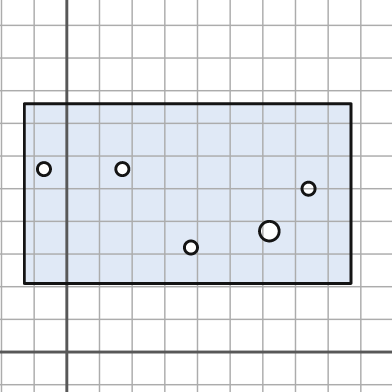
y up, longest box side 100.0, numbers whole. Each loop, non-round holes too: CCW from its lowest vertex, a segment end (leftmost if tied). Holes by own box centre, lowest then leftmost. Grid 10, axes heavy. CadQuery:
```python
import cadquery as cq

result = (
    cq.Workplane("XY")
    .moveTo(-13.0, 21.0)
    .lineTo(87.0, 21.0)
    .lineTo(87.0, 76.0)
    .lineTo(-13.0, 76.0)
    .close()
    .moveTo(38.0, 32.0)
    .circle(2.0)
    .moveTo(62.0, 37.0)
    .circle(3.0)
    .moveTo(74.0, 50.0)
    .circle(2.0)
    .moveTo(-7.0, 56.0)
    .circle(2.0)
    .moveTo(17.0, 56.0)
    .circle(2.0)
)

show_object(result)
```